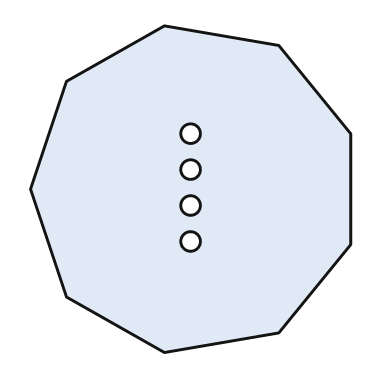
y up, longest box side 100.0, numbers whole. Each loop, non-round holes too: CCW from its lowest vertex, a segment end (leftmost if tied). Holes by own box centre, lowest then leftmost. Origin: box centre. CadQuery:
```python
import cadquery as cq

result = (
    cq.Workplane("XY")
    .moveTo(-8.0, -50.0)
    .lineTo(27.0, -44.0)
    .lineTo(49.0, -17.0)
    .lineTo(49.0, 17.0)
    .lineTo(27.0, 44.0)
    .lineTo(-8.0, 50.0)
    .lineTo(-38.0, 33.0)
    .lineTo(-49.0, 0.0)
    .lineTo(-38.0, -33.0)
    .close()
    .moveTo(0.0, -16.0)
    .circle(3.0)
    .moveTo(0.0, -5.0)
    .circle(3.0)
    .moveTo(0.0, 6.0)
    .circle(3.0)
    .moveTo(0.0, 17.0)
    .circle(3.0)
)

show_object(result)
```